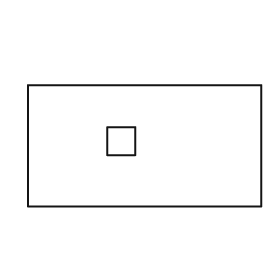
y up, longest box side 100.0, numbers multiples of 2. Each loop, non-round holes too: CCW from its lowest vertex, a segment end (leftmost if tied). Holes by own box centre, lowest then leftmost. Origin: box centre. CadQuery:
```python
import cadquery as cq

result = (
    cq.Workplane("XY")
    .moveTo(-50.0, -26.0)
    .lineTo(50.0, -26.0)
    .lineTo(50.0, 26.0)
    .lineTo(-50.0, 26.0)
    .close()
    .moveTo(-16.0, -4.0)
    .lineTo(-4.0, -4.0)
    .lineTo(-4.0, 8.0)
    .lineTo(-16.0, 8.0)
    .close()
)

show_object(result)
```